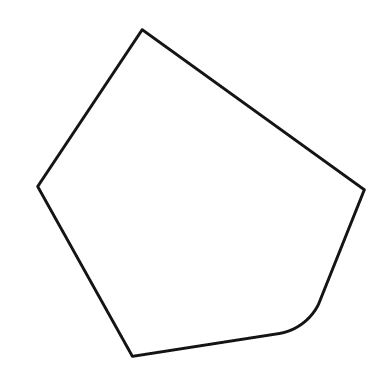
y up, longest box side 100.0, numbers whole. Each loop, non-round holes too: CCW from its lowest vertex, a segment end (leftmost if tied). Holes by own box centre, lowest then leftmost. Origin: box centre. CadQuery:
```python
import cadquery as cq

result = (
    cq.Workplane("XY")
    .moveTo(-21.0, -50.0)
    .lineTo(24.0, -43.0)
    .threePointArc((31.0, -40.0), (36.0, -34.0))
    .lineTo(50.0, 1.0)
    .lineTo(-18.0, 50.0)
    .lineTo(-50.0, 2.0)
    .close()
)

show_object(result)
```